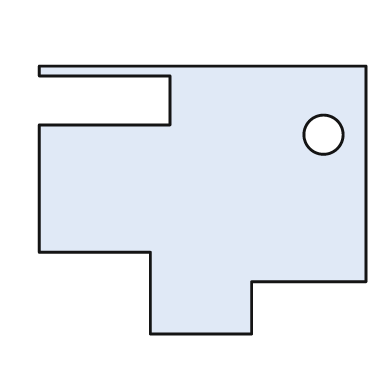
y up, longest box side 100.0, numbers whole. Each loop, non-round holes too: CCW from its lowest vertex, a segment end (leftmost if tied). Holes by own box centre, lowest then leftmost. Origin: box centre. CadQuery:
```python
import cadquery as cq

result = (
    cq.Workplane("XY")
    .moveTo(-16.0, -41.0)
    .lineTo(15.0, -41.0)
    .lineTo(15.0, -25.0)
    .lineTo(50.0, -25.0)
    .lineTo(50.0, 41.0)
    .lineTo(-50.0, 41.0)
    .lineTo(-50.0, 38.0)
    .lineTo(-10.0, 38.0)
    .lineTo(-10.0, 23.0)
    .lineTo(-50.0, 23.0)
    .lineTo(-50.0, -16.0)
    .lineTo(-16.0, -16.0)
    .close()
    .moveTo(37.0, 20.0)
    .circle(6.0)
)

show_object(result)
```